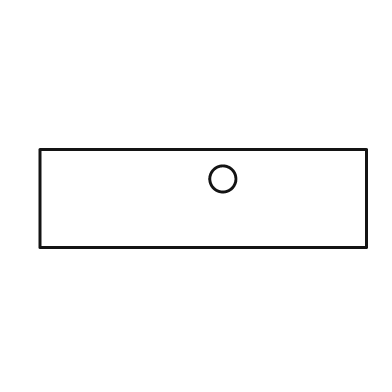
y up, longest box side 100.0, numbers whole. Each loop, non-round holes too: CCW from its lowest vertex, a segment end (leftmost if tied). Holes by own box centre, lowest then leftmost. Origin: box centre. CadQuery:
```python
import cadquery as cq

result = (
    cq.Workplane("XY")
    .moveTo(-50.0, -15.0)
    .lineTo(50.0, -15.0)
    .lineTo(50.0, 15.0)
    .lineTo(-50.0, 15.0)
    .close()
    .moveTo(6.0, 6.0)
    .circle(4.0)
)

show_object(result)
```